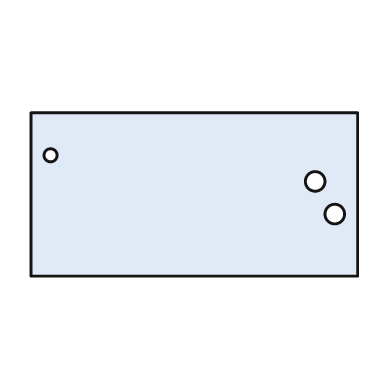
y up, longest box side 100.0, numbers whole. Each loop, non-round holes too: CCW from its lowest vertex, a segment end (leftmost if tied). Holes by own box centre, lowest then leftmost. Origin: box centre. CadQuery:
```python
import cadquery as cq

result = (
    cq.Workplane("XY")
    .moveTo(-50.0, -25.0)
    .lineTo(50.0, -25.0)
    .lineTo(50.0, 25.0)
    .lineTo(-50.0, 25.0)
    .close()
    .moveTo(43.0, -6.0)
    .circle(3.0)
    .moveTo(37.0, 4.0)
    .circle(3.0)
    .moveTo(-44.0, 12.0)
    .circle(2.0)
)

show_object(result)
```